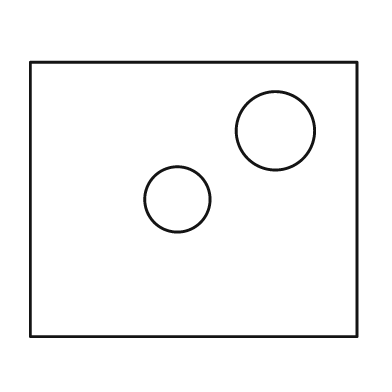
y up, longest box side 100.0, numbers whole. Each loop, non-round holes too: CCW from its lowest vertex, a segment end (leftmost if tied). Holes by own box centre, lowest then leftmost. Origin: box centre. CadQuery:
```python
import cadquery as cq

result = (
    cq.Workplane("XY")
    .moveTo(-50.0, -42.0)
    .lineTo(50.0, -42.0)
    .lineTo(50.0, 42.0)
    .lineTo(-50.0, 42.0)
    .close()
    .moveTo(-5.0, 0.0)
    .circle(10.0)
    .moveTo(25.0, 21.0)
    .circle(12.0)
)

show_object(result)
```